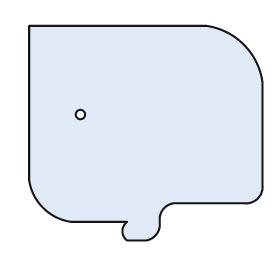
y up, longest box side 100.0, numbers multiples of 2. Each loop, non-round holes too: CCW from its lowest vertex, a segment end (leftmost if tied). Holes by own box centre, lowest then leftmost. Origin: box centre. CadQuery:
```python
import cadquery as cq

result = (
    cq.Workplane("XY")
    .moveTo(-8.0, -46.0)
    .lineTo(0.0, -46.0)
    .threePointArc((4.0, -44.0), (6.0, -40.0))
    .lineTo(6.0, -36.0)
    .threePointArc((8.0, -32.0), (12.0, -30.0))
    .lineTo(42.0, -30.0)
    .threePointArc((48.0, -28.0), (50.0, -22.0))
    .lineTo(50.0, 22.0)
    .threePointArc((42.0, 38.0), (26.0, 46.0))
    .lineTo(-50.0, 46.0)
    .lineTo(-50.0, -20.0)
    .threePointArc((-44.0, -32.0), (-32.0, -38.0))
    .lineTo(-8.0, -38.0)
    .threePointArc((-10.0, -42.0), (-8.0, -46.0))
    .close()
    .moveTo(-28.0, 8.0)
    .circle(2.0)
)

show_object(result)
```